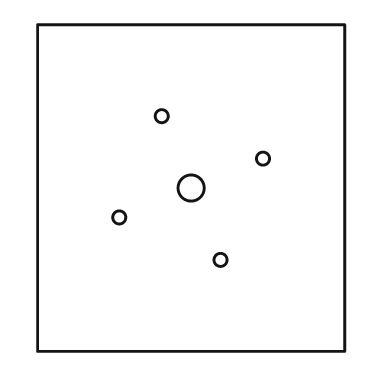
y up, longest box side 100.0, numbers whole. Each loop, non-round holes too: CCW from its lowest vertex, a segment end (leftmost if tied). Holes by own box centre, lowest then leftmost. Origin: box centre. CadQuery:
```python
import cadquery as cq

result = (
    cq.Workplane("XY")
    .moveTo(-47.0, -50.0)
    .lineTo(47.0, -50.0)
    .lineTo(47.0, 50.0)
    .lineTo(-47.0, 50.0)
    .close()
    .moveTo(9.0, -22.0)
    .circle(2.0)
    .moveTo(-22.0, -9.0)
    .circle(2.0)
    .moveTo(0.0, 0.0)
    .circle(4.0)
    .moveTo(22.0, 9.0)
    .circle(2.0)
    .moveTo(-9.0, 22.0)
    .circle(2.0)
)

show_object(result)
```